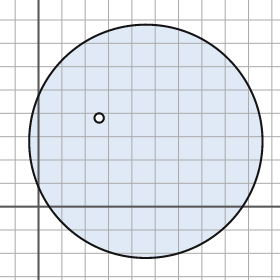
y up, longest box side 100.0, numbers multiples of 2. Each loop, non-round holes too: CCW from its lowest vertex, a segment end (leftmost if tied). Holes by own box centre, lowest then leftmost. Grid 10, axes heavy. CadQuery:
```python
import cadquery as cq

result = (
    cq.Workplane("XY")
    .moveTo(46.0, 28.0)
    .circle(50.0)
    .moveTo(26.0, 38.0)
    .circle(2.0)
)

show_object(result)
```